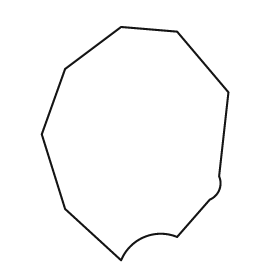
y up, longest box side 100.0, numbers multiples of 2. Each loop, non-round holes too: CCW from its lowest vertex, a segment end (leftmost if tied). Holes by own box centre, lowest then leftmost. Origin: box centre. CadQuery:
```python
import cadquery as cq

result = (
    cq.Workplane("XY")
    .moveTo(-6.0, -50.0)
    .threePointArc((4.0, -40.0), (18.0, -40.0))
    .lineTo(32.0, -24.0)
    .threePointArc((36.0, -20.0), (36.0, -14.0))
    .lineTo(40.0, 22.0)
    .lineTo(18.0, 48.0)
    .lineTo(-6.0, 50.0)
    .lineTo(-30.0, 32.0)
    .lineTo(-40.0, 4.0)
    .lineTo(-30.0, -28.0)
    .close()
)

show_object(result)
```